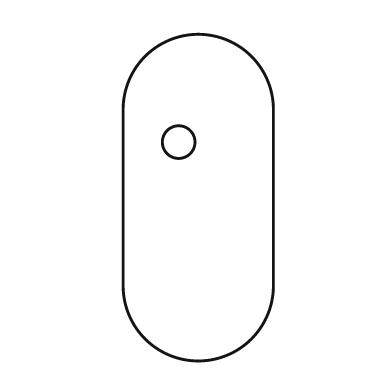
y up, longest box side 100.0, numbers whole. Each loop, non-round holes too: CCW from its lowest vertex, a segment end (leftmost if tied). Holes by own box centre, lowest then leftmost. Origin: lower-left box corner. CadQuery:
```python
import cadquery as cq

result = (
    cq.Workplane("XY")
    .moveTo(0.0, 23.0)
    .threePointArc((23.0, 0.0), (46.0, 23.0))
    .lineTo(46.0, 77.0)
    .threePointArc((23.0, 100.0), (0.0, 77.0))
    .close()
    .moveTo(17.0, 67.0)
    .circle(5.0)
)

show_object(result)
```